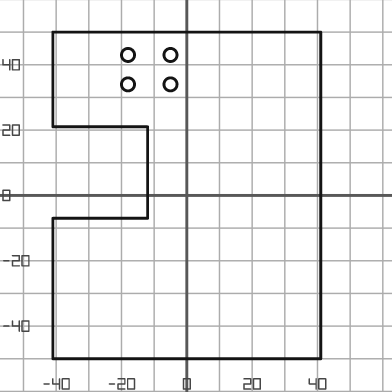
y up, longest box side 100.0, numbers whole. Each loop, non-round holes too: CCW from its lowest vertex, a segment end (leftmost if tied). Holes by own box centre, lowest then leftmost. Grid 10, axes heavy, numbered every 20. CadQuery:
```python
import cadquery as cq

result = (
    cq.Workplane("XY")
    .moveTo(-41.0, -50.0)
    .lineTo(41.0, -50.0)
    .lineTo(41.0, 50.0)
    .lineTo(-41.0, 50.0)
    .lineTo(-41.0, 21.0)
    .lineTo(-12.0, 21.0)
    .lineTo(-12.0, -7.0)
    .lineTo(-41.0, -7.0)
    .close()
    .moveTo(-18.0, 34.0)
    .circle(2.0)
    .moveTo(-5.0, 34.0)
    .circle(2.0)
    .moveTo(-18.0, 43.0)
    .circle(2.0)
    .moveTo(-5.0, 43.0)
    .circle(2.0)
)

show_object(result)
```